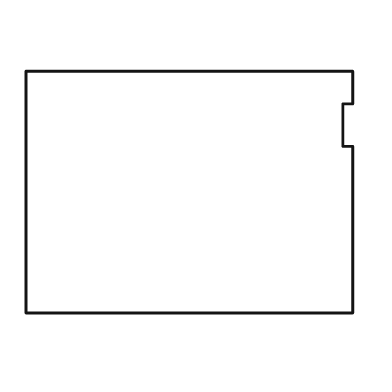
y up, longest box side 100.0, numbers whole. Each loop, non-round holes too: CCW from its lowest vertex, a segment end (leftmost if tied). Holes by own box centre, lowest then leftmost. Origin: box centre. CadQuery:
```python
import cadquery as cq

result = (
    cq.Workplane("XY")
    .moveTo(-50.0, -37.0)
    .lineTo(50.0, -37.0)
    .lineTo(50.0, 14.0)
    .lineTo(47.0, 14.0)
    .lineTo(47.0, 27.0)
    .lineTo(50.0, 27.0)
    .lineTo(50.0, 37.0)
    .lineTo(-50.0, 37.0)
    .close()
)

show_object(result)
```